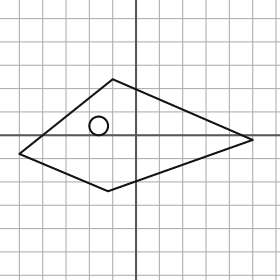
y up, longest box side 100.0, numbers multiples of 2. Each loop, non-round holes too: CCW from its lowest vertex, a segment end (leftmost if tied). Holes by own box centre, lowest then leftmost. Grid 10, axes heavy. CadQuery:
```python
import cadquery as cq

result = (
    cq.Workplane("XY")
    .moveTo(-12.0, -24.0)
    .lineTo(50.0, -2.0)
    .lineTo(-10.0, 24.0)
    .lineTo(-50.0, -8.0)
    .close()
    .moveTo(-16.0, 4.0)
    .circle(4.0)
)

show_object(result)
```